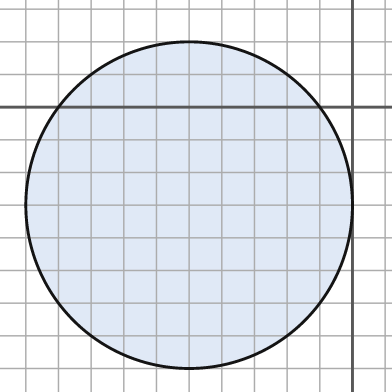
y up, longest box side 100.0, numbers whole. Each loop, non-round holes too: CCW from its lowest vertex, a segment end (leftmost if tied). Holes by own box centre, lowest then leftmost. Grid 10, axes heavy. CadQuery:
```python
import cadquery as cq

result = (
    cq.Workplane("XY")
    .moveTo(-50.0, -30.0)
    .circle(50.0)
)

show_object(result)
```